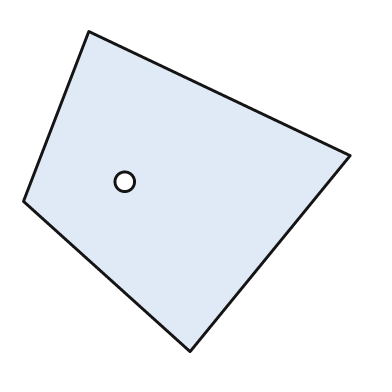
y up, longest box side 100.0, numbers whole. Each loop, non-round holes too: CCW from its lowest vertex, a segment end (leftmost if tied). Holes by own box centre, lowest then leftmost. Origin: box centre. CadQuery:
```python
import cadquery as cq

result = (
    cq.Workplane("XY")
    .moveTo(1.0, -49.0)
    .lineTo(50.0, 11.0)
    .lineTo(-30.0, 49.0)
    .lineTo(-50.0, -3.0)
    .close()
    .moveTo(-19.0, 3.0)
    .circle(3.0)
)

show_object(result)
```